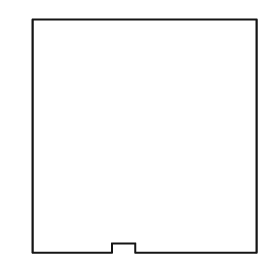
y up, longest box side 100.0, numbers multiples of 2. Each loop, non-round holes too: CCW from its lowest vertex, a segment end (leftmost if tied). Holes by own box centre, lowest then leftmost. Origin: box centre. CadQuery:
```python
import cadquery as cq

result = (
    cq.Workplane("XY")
    .moveTo(-48.0, -50.0)
    .lineTo(-14.0, -50.0)
    .lineTo(-14.0, -46.0)
    .lineTo(-4.0, -46.0)
    .lineTo(-4.0, -50.0)
    .lineTo(48.0, -50.0)
    .lineTo(48.0, 50.0)
    .lineTo(-48.0, 50.0)
    .close()
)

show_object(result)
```